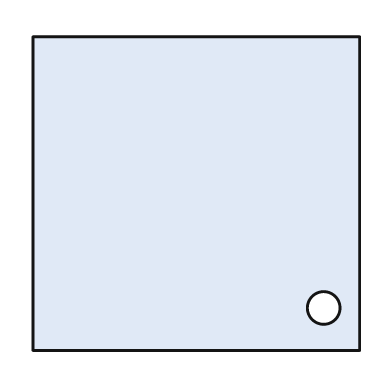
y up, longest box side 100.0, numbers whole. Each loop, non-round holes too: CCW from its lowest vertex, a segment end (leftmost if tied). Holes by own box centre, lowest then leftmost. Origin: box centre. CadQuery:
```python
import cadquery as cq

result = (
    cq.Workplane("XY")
    .moveTo(-50.0, -48.0)
    .lineTo(50.0, -48.0)
    .lineTo(50.0, 48.0)
    .lineTo(-50.0, 48.0)
    .close()
    .moveTo(39.0, -35.0)
    .circle(5.0)
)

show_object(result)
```